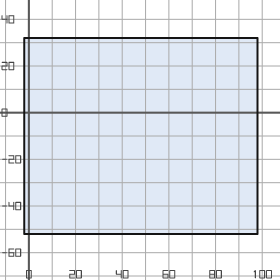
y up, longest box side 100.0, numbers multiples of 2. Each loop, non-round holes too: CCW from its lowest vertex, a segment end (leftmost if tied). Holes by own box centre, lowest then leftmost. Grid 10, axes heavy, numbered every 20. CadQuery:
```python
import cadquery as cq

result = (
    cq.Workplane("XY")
    .moveTo(-2.0, -52.0)
    .lineTo(98.0, -52.0)
    .lineTo(98.0, 32.0)
    .lineTo(-2.0, 32.0)
    .close()
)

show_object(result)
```